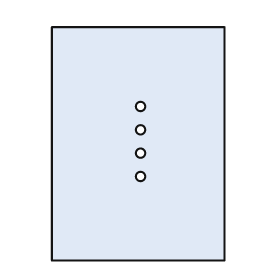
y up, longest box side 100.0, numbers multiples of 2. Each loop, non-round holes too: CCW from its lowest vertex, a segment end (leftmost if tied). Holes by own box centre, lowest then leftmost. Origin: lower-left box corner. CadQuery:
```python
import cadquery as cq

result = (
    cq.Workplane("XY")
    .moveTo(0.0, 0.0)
    .lineTo(74.0, 0.0)
    .lineTo(74.0, 100.0)
    .lineTo(0.0, 100.0)
    .close()
    .moveTo(38.0, 36.0)
    .circle(2.0)
    .moveTo(38.0, 46.0)
    .circle(2.0)
    .moveTo(38.0, 56.0)
    .circle(2.0)
    .moveTo(38.0, 66.0)
    .circle(2.0)
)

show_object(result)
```